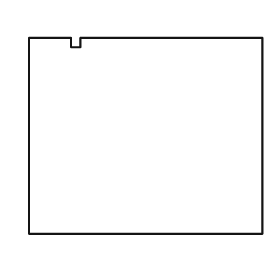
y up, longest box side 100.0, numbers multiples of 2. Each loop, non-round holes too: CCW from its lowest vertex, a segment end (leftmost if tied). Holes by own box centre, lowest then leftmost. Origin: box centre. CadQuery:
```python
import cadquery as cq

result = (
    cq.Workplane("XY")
    .moveTo(-50.0, -42.0)
    .lineTo(50.0, -42.0)
    .lineTo(50.0, 42.0)
    .lineTo(-28.0, 42.0)
    .lineTo(-28.0, 38.0)
    .lineTo(-32.0, 38.0)
    .lineTo(-32.0, 42.0)
    .lineTo(-50.0, 42.0)
    .close()
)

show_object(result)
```